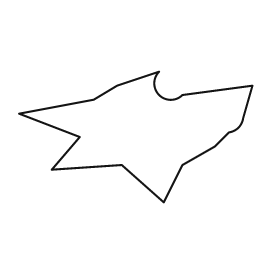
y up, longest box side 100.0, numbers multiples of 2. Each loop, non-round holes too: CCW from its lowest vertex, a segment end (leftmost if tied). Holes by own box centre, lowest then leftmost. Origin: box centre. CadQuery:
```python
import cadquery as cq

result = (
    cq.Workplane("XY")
    .moveTo(12.0, -28.0)
    .lineTo(20.0, -12.0)
    .lineTo(34.0, -4.0)
    .lineTo(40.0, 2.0)
    .threePointArc((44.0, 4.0), (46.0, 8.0))
    .lineTo(50.0, 22.0)
    .lineTo(20.0, 18.0)
    .threePointArc((10.0, 18.0), (10.0, 28.0))
    .lineTo(-8.0, 22.0)
    .lineTo(-18.0, 16.0)
    .lineTo(-50.0, 10.0)
    .lineTo(-24.0, 0.0)
    .lineTo(-36.0, -14.0)
    .lineTo(-6.0, -12.0)
    .close()
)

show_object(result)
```